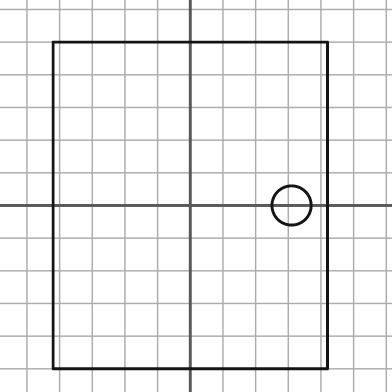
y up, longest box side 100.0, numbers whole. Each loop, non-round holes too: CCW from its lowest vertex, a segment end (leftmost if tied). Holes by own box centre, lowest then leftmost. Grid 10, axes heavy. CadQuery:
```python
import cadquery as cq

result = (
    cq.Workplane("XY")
    .moveTo(-42.0, -50.0)
    .lineTo(42.0, -50.0)
    .lineTo(42.0, 50.0)
    .lineTo(-42.0, 50.0)
    .close()
    .moveTo(31.0, 0.0)
    .circle(6.0)
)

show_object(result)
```